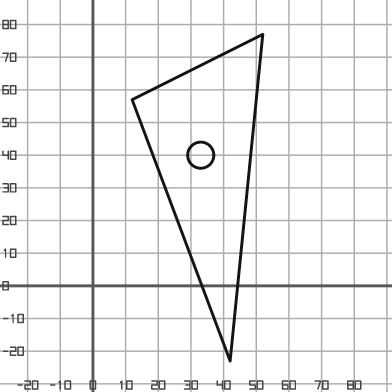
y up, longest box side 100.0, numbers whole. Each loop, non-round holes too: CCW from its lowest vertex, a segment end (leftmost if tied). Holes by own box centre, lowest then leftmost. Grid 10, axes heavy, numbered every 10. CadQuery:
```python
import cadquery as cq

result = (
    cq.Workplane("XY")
    .moveTo(42.0, -23.0)
    .lineTo(52.0, 77.0)
    .lineTo(12.0, 57.0)
    .close()
    .moveTo(33.0, 40.0)
    .circle(4.0)
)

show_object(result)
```